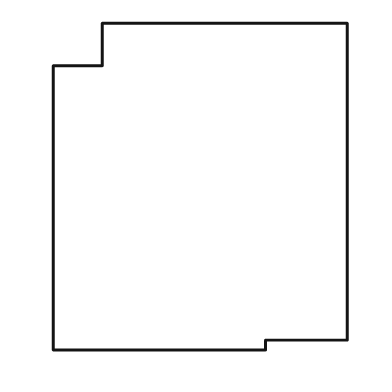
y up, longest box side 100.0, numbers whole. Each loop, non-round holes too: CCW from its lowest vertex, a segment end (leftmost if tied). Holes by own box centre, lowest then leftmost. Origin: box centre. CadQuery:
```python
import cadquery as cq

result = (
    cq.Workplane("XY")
    .moveTo(-45.0, -50.0)
    .lineTo(20.0, -50.0)
    .lineTo(20.0, -47.0)
    .lineTo(45.0, -47.0)
    .lineTo(45.0, 50.0)
    .lineTo(-30.0, 50.0)
    .lineTo(-30.0, 37.0)
    .lineTo(-45.0, 37.0)
    .close()
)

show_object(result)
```